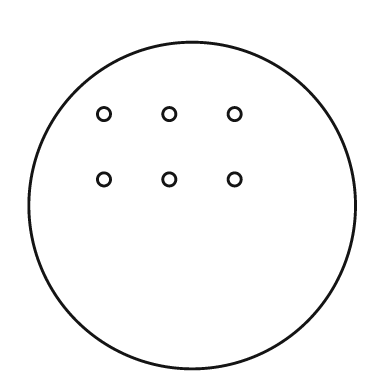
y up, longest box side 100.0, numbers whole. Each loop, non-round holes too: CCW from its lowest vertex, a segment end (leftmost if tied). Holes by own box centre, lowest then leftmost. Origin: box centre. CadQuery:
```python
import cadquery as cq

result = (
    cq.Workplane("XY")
    .moveTo(0.0, 0.0)
    .circle(50.0)
    .moveTo(-27.0, 8.0)
    .circle(2.0)
    .moveTo(-7.0, 8.0)
    .circle(2.0)
    .moveTo(13.0, 8.0)
    .circle(2.0)
    .moveTo(-27.0, 28.0)
    .circle(2.0)
    .moveTo(-7.0, 28.0)
    .circle(2.0)
    .moveTo(13.0, 28.0)
    .circle(2.0)
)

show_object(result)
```